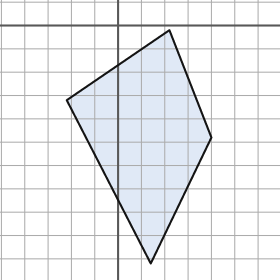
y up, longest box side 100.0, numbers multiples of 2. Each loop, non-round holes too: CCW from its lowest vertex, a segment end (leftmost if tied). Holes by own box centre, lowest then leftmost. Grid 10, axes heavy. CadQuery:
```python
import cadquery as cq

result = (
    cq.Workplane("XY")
    .moveTo(14.0, -102.0)
    .lineTo(40.0, -48.0)
    .lineTo(22.0, -2.0)
    .lineTo(-22.0, -32.0)
    .close()
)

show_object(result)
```